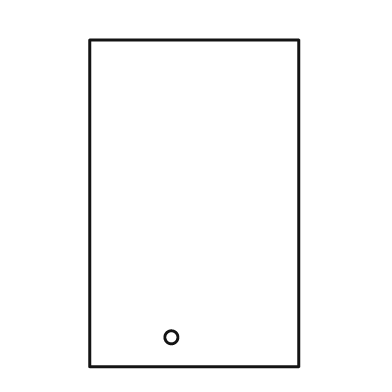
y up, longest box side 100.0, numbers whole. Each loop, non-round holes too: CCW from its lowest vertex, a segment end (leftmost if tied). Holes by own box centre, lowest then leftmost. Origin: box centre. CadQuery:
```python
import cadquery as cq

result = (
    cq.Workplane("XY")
    .moveTo(-32.0, -50.0)
    .lineTo(32.0, -50.0)
    .lineTo(32.0, 50.0)
    .lineTo(-32.0, 50.0)
    .close()
    .moveTo(-7.0, -41.0)
    .circle(2.0)
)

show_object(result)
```